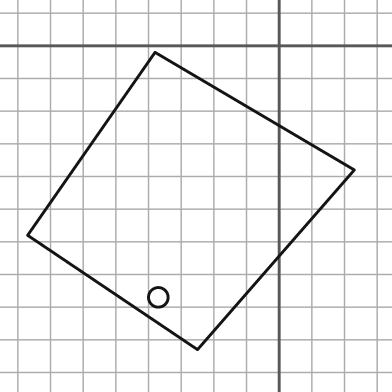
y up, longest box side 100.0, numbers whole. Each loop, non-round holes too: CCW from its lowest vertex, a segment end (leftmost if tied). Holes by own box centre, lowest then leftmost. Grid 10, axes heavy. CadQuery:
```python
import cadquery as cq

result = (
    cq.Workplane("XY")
    .moveTo(-25.0, -93.0)
    .lineTo(23.0, -38.0)
    .lineTo(-38.0, -2.0)
    .lineTo(-77.0, -58.0)
    .close()
    .moveTo(-37.0, -77.0)
    .circle(3.0)
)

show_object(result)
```